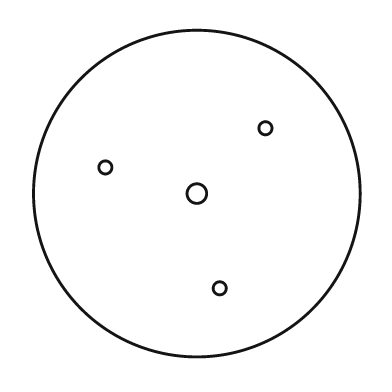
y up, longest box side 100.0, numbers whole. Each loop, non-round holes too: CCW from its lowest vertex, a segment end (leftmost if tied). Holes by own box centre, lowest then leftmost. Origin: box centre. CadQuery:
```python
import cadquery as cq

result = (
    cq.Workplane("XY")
    .moveTo(0.0, 0.0)
    .circle(50.0)
    .moveTo(7.0, -29.0)
    .circle(2.0)
    .moveTo(0.0, 0.0)
    .circle(3.0)
    .moveTo(-28.0, 8.0)
    .circle(2.0)
    .moveTo(21.0, 20.0)
    .circle(2.0)
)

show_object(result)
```